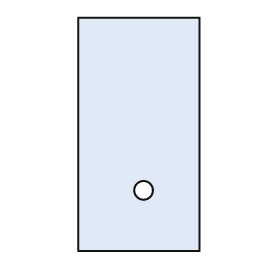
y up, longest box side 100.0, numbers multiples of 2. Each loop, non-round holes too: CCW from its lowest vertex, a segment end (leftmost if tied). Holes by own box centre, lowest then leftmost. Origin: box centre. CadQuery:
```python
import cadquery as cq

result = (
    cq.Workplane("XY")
    .moveTo(-26.0, -50.0)
    .lineTo(26.0, -50.0)
    .lineTo(26.0, 50.0)
    .lineTo(-26.0, 50.0)
    .close()
    .moveTo(2.0, -24.0)
    .circle(4.0)
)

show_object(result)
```